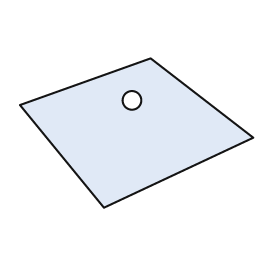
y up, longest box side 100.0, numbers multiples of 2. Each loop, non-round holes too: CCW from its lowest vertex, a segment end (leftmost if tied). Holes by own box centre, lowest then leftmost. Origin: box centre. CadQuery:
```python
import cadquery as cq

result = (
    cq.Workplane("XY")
    .moveTo(-14.0, -32.0)
    .lineTo(50.0, -2.0)
    .lineTo(6.0, 32.0)
    .lineTo(-50.0, 12.0)
    .close()
    .moveTo(-2.0, 14.0)
    .circle(4.0)
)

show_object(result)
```